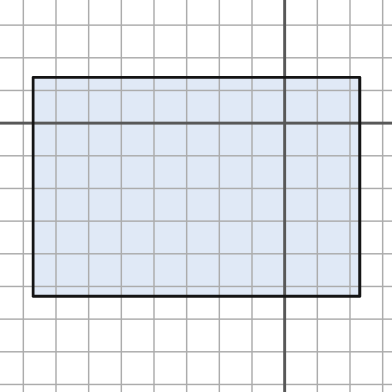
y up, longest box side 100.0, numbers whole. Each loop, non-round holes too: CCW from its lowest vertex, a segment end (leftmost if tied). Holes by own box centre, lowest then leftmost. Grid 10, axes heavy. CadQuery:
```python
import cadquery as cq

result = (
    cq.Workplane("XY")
    .moveTo(-77.0, -53.0)
    .lineTo(23.0, -53.0)
    .lineTo(23.0, 14.0)
    .lineTo(-77.0, 14.0)
    .close()
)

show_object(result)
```